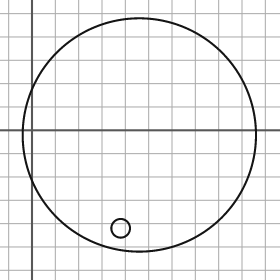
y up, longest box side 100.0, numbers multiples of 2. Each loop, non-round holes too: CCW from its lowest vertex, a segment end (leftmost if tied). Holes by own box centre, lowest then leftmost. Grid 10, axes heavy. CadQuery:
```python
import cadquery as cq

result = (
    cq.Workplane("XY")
    .moveTo(46.0, -2.0)
    .circle(50.0)
    .moveTo(38.0, -42.0)
    .circle(4.0)
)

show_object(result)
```